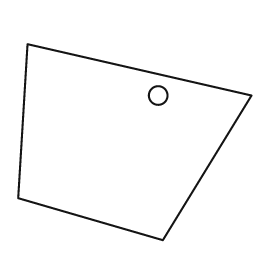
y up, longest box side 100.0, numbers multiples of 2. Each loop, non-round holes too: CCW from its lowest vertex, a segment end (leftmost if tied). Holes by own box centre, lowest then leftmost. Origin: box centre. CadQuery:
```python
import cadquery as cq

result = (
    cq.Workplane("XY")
    .moveTo(12.0, -42.0)
    .lineTo(50.0, 20.0)
    .lineTo(-46.0, 42.0)
    .lineTo(-50.0, -24.0)
    .close()
    .moveTo(10.0, 20.0)
    .circle(4.0)
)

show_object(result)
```